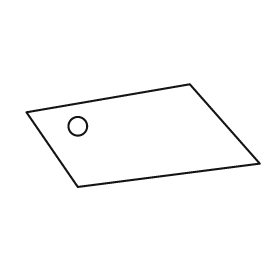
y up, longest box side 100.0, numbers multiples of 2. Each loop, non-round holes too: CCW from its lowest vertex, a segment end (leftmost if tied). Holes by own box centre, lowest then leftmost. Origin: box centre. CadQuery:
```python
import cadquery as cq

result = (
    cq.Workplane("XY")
    .moveTo(-28.0, -22.0)
    .lineTo(50.0, -12.0)
    .lineTo(20.0, 22.0)
    .lineTo(-50.0, 10.0)
    .close()
    .moveTo(-28.0, 4.0)
    .circle(4.0)
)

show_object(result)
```